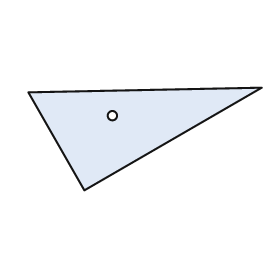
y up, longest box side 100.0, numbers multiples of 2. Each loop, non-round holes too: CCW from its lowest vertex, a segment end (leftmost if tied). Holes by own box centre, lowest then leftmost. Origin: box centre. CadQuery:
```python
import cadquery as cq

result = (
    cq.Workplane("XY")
    .moveTo(-26.0, -22.0)
    .lineTo(50.0, 22.0)
    .lineTo(-50.0, 20.0)
    .close()
    .moveTo(-14.0, 10.0)
    .circle(2.0)
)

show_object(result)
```